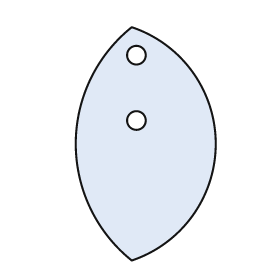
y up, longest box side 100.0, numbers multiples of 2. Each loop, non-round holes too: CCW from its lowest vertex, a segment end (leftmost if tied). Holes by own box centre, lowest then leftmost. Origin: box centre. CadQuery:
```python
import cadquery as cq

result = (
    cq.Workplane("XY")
    .moveTo(-6.0, -50.0)
    .threePointArc((30.0, 0.0), (-6.0, 50.0))
    .threePointArc((-30.0, 0.0), (-6.0, -50.0))
    .close()
    .moveTo(-4.0, 10.0)
    .circle(4.0)
    .moveTo(-4.0, 38.0)
    .circle(4.0)
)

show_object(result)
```